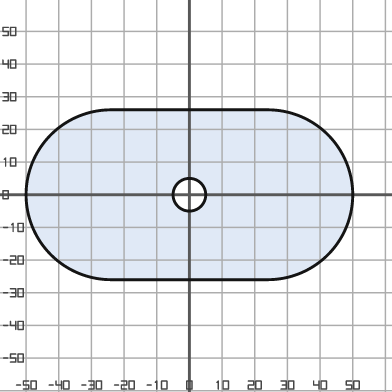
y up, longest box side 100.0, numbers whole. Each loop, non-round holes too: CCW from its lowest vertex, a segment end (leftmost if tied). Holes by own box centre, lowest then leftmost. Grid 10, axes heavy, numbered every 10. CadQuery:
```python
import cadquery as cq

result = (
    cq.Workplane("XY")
    .moveTo(-24.0, -26.0)
    .lineTo(24.0, -26.0)
    .threePointArc((50.0, 0.0), (24.0, 26.0))
    .lineTo(-24.0, 26.0)
    .threePointArc((-50.0, 0.0), (-24.0, -26.0))
    .close()
    .moveTo(0.0, 0.0)
    .circle(5.0)
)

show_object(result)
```